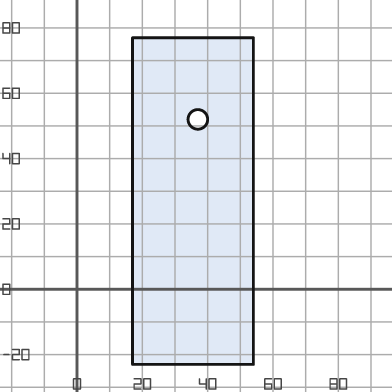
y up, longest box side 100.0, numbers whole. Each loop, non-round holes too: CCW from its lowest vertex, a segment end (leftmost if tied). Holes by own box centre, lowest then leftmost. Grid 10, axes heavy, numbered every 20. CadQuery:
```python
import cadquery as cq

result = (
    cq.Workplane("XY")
    .moveTo(17.0, -23.0)
    .lineTo(54.0, -23.0)
    .lineTo(54.0, 77.0)
    .lineTo(17.0, 77.0)
    .close()
    .moveTo(37.0, 52.0)
    .circle(3.0)
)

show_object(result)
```